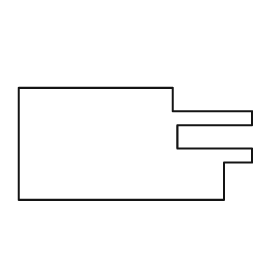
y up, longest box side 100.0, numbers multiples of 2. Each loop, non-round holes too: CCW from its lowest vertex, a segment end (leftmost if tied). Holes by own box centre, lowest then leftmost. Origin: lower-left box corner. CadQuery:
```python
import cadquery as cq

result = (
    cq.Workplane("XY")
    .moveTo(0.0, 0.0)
    .lineTo(88.0, 0.0)
    .lineTo(88.0, 16.0)
    .lineTo(100.0, 16.0)
    .lineTo(100.0, 22.0)
    .lineTo(68.0, 22.0)
    .lineTo(68.0, 32.0)
    .lineTo(100.0, 32.0)
    .lineTo(100.0, 38.0)
    .lineTo(66.0, 38.0)
    .lineTo(66.0, 48.0)
    .lineTo(0.0, 48.0)
    .close()
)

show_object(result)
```